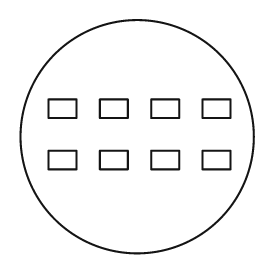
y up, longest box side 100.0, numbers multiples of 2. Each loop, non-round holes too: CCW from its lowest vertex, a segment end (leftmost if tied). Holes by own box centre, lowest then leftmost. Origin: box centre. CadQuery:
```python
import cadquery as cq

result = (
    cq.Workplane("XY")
    .moveTo(0.0, 0.0)
    .circle(50.0)
    .moveTo(-38.0, -14.0)
    .lineTo(-26.0, -14.0)
    .lineTo(-26.0, -6.0)
    .lineTo(-38.0, -6.0)
    .close()
    .moveTo(-16.0, -14.0)
    .lineTo(-4.0, -14.0)
    .lineTo(-4.0, -6.0)
    .lineTo(-16.0, -6.0)
    .close()
    .moveTo(6.0, -14.0)
    .lineTo(18.0, -14.0)
    .lineTo(18.0, -6.0)
    .lineTo(6.0, -6.0)
    .close()
    .moveTo(28.0, -14.0)
    .lineTo(40.0, -14.0)
    .lineTo(40.0, -6.0)
    .lineTo(28.0, -6.0)
    .close()
    .moveTo(-38.0, 8.0)
    .lineTo(-26.0, 8.0)
    .lineTo(-26.0, 16.0)
    .lineTo(-38.0, 16.0)
    .close()
    .moveTo(-16.0, 8.0)
    .lineTo(-4.0, 8.0)
    .lineTo(-4.0, 16.0)
    .lineTo(-16.0, 16.0)
    .close()
    .moveTo(6.0, 8.0)
    .lineTo(18.0, 8.0)
    .lineTo(18.0, 16.0)
    .lineTo(6.0, 16.0)
    .close()
    .moveTo(28.0, 8.0)
    .lineTo(40.0, 8.0)
    .lineTo(40.0, 16.0)
    .lineTo(28.0, 16.0)
    .close()
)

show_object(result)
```